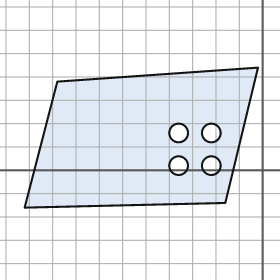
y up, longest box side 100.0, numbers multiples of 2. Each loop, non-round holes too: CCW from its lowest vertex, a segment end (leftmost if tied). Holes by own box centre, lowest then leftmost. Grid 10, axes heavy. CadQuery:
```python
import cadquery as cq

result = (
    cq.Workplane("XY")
    .moveTo(-102.0, -16.0)
    .lineTo(-16.0, -14.0)
    .lineTo(-2.0, 44.0)
    .lineTo(-88.0, 38.0)
    .close()
    .moveTo(-36.0, 2.0)
    .circle(4.0)
    .moveTo(-22.0, 2.0)
    .circle(4.0)
    .moveTo(-36.0, 16.0)
    .circle(4.0)
    .moveTo(-22.0, 16.0)
    .circle(4.0)
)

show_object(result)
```